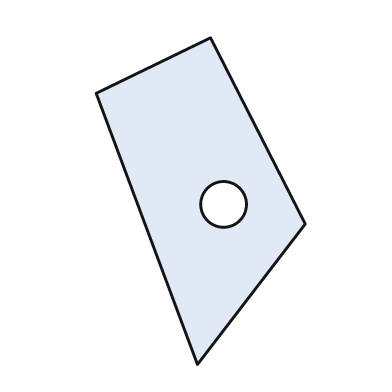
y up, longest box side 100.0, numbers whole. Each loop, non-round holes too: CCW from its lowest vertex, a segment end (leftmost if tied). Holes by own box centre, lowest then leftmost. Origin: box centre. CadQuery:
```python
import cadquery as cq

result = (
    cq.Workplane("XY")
    .moveTo(-1.0, -50.0)
    .lineTo(32.0, -7.0)
    .lineTo(3.0, 50.0)
    .lineTo(-32.0, 33.0)
    .close()
    .moveTo(7.0, -1.0)
    .circle(7.0)
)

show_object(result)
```